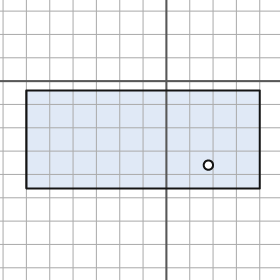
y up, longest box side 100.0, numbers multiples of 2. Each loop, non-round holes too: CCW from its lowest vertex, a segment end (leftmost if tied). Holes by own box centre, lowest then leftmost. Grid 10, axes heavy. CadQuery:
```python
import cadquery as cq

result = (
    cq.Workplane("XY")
    .moveTo(-60.0, -46.0)
    .lineTo(40.0, -46.0)
    .lineTo(40.0, -4.0)
    .lineTo(-60.0, -4.0)
    .close()
    .moveTo(18.0, -36.0)
    .circle(2.0)
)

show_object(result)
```